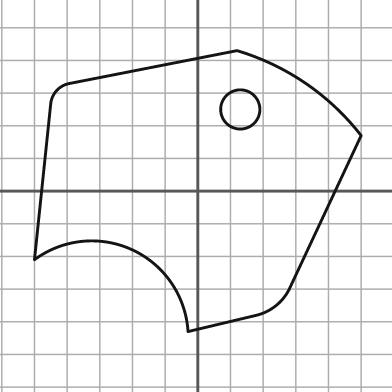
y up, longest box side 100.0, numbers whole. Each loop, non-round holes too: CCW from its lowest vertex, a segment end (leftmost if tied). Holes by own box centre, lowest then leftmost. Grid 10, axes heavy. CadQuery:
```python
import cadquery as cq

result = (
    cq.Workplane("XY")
    .moveTo(-3.0, -43.0)
    .lineTo(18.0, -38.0)
    .threePointArc((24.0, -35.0), (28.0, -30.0))
    .lineTo(50.0, 17.0)
    .threePointArc((33.0, 33.0), (12.0, 43.0))
    .lineTo(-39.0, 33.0)
    .threePointArc((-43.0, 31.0), (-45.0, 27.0))
    .lineTo(-50.0, -21.0)
    .threePointArc((-20.0, -18.0), (-3.0, -43.0))
    .close()
    .moveTo(13.0, 25.0)
    .circle(6.0)
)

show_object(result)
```